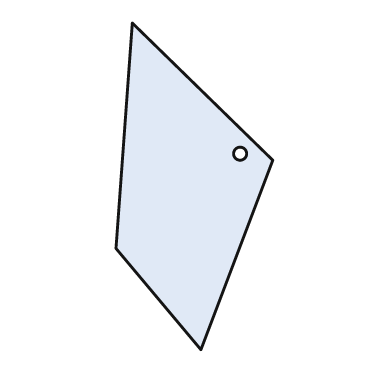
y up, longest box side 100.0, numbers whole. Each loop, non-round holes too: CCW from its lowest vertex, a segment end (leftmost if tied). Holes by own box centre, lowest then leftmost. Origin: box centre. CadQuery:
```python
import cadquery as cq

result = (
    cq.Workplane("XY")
    .moveTo(2.0, -50.0)
    .lineTo(24.0, 8.0)
    .lineTo(-19.0, 50.0)
    .lineTo(-24.0, -19.0)
    .close()
    .moveTo(14.0, 10.0)
    .circle(2.0)
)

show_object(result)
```